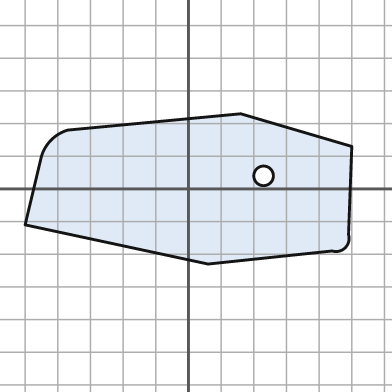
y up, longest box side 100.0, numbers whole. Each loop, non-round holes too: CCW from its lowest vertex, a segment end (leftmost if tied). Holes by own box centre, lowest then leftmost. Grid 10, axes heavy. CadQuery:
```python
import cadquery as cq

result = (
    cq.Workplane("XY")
    .moveTo(6.0, -23.0)
    .lineTo(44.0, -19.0)
    .threePointArc((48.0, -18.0), (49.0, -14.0))
    .lineTo(50.0, 13.0)
    .lineTo(16.0, 23.0)
    .lineTo(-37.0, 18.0)
    .threePointArc((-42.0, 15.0), (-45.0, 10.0))
    .lineTo(-50.0, -11.0)
    .close()
    .moveTo(23.0, 4.0)
    .circle(3.0)
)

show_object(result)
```